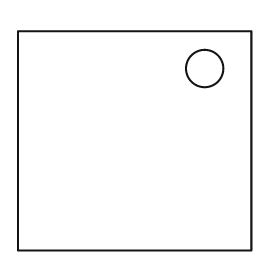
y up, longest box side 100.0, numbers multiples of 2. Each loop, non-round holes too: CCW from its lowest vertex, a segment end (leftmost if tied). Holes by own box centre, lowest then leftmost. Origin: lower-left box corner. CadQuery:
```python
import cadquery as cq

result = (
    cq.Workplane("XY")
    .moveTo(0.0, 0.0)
    .lineTo(100.0, 0.0)
    .lineTo(100.0, 94.0)
    .lineTo(0.0, 94.0)
    .close()
    .moveTo(80.0, 78.0)
    .circle(8.0)
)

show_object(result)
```